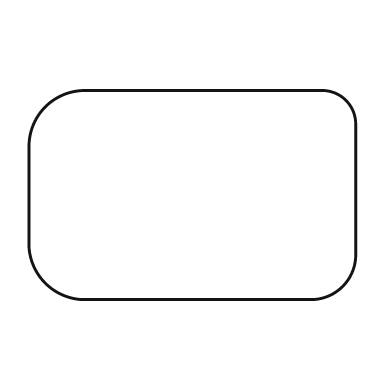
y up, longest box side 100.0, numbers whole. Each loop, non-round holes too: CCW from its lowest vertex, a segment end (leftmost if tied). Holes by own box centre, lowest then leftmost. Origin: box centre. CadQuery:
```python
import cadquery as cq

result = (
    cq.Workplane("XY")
    .moveTo(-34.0, -32.0)
    .lineTo(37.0, -32.0)
    .threePointArc((46.0, -28.0), (50.0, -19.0))
    .lineTo(50.0, 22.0)
    .threePointArc((47.0, 29.0), (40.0, 32.0))
    .lineTo(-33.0, 32.0)
    .threePointArc((-45.0, 27.0), (-50.0, 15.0))
    .lineTo(-50.0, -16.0)
    .threePointArc((-45.0, -27.0), (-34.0, -32.0))
    .close()
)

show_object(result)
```